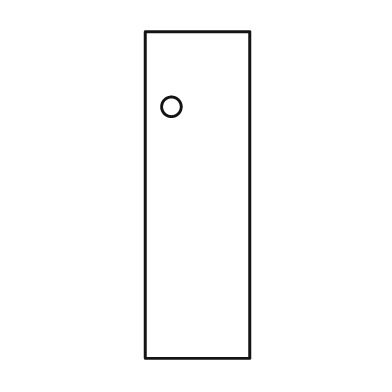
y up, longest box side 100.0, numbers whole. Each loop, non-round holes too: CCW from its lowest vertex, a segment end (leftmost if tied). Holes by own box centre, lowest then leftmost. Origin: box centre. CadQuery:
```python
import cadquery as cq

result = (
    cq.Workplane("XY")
    .moveTo(-16.0, -50.0)
    .lineTo(16.0, -50.0)
    .lineTo(16.0, 50.0)
    .lineTo(-16.0, 50.0)
    .close()
    .moveTo(-8.0, 27.0)
    .circle(3.0)
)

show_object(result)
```